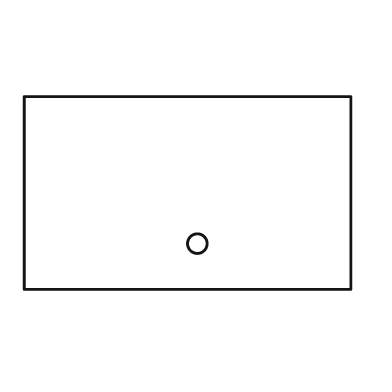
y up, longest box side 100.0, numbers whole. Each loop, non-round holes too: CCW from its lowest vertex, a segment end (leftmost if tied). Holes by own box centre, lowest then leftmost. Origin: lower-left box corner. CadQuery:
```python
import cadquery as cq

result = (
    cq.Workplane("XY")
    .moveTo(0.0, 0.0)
    .lineTo(100.0, 0.0)
    .lineTo(100.0, 59.0)
    .lineTo(0.0, 59.0)
    .close()
    .moveTo(53.0, 14.0)
    .circle(3.0)
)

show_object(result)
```